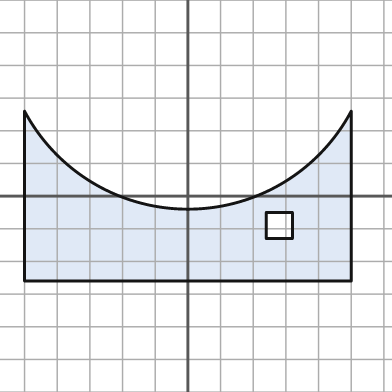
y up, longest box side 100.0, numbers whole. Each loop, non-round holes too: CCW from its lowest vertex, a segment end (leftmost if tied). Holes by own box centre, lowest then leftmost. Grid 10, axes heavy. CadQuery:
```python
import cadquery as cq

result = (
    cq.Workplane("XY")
    .moveTo(-50.0, -26.0)
    .lineTo(50.0, -26.0)
    .lineTo(50.0, 26.0)
    .threePointArc((0.0, -4.0), (-50.0, 26.0))
    .close()
    .moveTo(24.0, -13.0)
    .lineTo(32.0, -13.0)
    .lineTo(32.0, -5.0)
    .lineTo(24.0, -5.0)
    .close()
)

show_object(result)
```